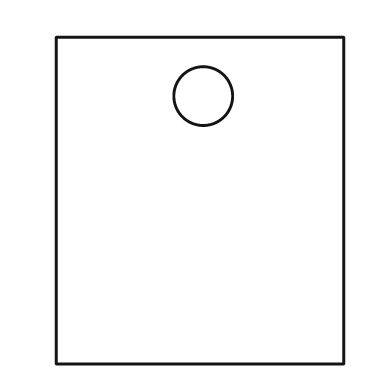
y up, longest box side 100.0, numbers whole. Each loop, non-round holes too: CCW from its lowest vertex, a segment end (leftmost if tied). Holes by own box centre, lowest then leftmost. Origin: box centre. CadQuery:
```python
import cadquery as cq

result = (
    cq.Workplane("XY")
    .moveTo(-44.0, -50.0)
    .lineTo(44.0, -50.0)
    .lineTo(44.0, 50.0)
    .lineTo(-44.0, 50.0)
    .close()
    .moveTo(1.0, 32.0)
    .circle(9.0)
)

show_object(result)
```